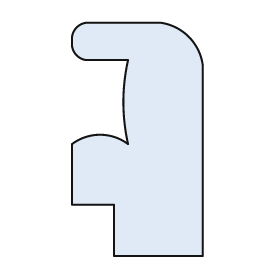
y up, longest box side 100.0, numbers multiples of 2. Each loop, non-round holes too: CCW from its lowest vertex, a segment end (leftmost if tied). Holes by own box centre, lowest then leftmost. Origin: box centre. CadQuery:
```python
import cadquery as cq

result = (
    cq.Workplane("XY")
    .moveTo(-10.0, -50.0)
    .lineTo(28.0, -50.0)
    .lineTo(28.0, 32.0)
    .threePointArc((22.0, 44.0), (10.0, 50.0))
    .lineTo(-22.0, 50.0)
    .threePointArc((-26.0, 48.0), (-28.0, 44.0))
    .lineTo(-28.0, 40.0)
    .threePointArc((-26.0, 36.0), (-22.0, 34.0))
    .lineTo(-4.0, 34.0)
    .threePointArc((-6.0, 16.0), (-4.0, -2.0))
    .threePointArc((-16.0, 2.0), (-28.0, -2.0))
    .lineTo(-28.0, -28.0)
    .lineTo(-10.0, -28.0)
    .close()
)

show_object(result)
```